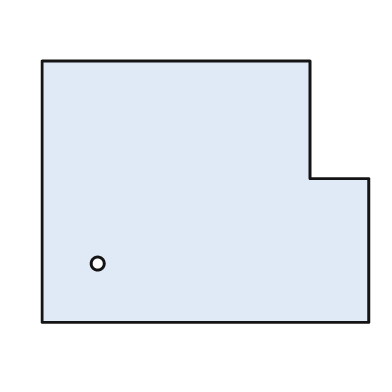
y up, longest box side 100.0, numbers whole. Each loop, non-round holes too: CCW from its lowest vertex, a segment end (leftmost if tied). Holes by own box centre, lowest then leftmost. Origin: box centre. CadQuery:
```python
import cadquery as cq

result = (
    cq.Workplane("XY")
    .moveTo(-50.0, -40.0)
    .lineTo(50.0, -40.0)
    .lineTo(50.0, 4.0)
    .lineTo(32.0, 4.0)
    .lineTo(32.0, 40.0)
    .lineTo(-50.0, 40.0)
    .close()
    .moveTo(-33.0, -22.0)
    .circle(2.0)
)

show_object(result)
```